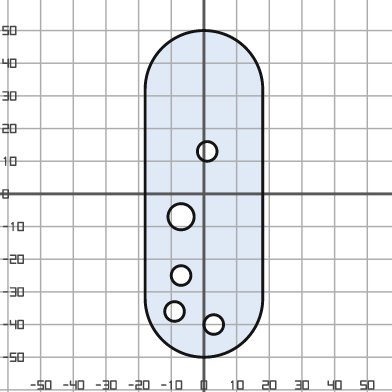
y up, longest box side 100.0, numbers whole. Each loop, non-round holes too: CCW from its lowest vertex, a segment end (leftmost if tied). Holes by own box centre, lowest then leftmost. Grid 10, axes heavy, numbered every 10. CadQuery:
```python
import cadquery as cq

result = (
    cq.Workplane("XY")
    .moveTo(-18.0, -32.0)
    .threePointArc((0.0, -50.0), (18.0, -32.0))
    .lineTo(18.0, 32.0)
    .threePointArc((0.0, 50.0), (-18.0, 32.0))
    .close()
    .moveTo(3.0, -40.0)
    .circle(3.0)
    .moveTo(-9.0, -36.0)
    .circle(3.0)
    .moveTo(-7.0, -25.0)
    .circle(3.0)
    .moveTo(-7.0, -7.0)
    .circle(4.0)
    .moveTo(1.0, 13.0)
    .circle(3.0)
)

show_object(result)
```